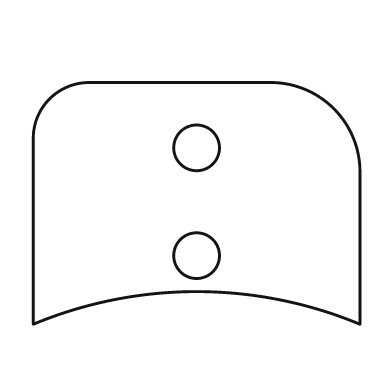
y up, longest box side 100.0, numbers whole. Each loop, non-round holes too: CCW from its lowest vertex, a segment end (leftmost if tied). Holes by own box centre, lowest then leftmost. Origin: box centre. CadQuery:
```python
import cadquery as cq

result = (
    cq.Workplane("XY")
    .moveTo(-50.0, -37.0)
    .threePointArc((0.0, -27.0), (50.0, -37.0))
    .lineTo(50.0, 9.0)
    .threePointArc((42.0, 29.0), (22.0, 37.0))
    .lineTo(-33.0, 37.0)
    .threePointArc((-45.0, 32.0), (-50.0, 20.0))
    .close()
    .moveTo(0.0, -16.0)
    .circle(7.0)
    .moveTo(0.0, 17.0)
    .circle(7.0)
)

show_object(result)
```